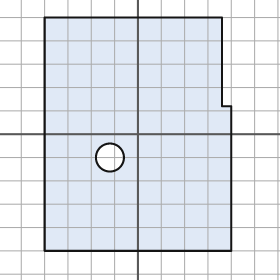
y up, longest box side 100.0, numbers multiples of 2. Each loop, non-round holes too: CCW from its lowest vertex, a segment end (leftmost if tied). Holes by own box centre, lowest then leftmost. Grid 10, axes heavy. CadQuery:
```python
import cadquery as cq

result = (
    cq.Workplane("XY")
    .moveTo(-40.0, -50.0)
    .lineTo(40.0, -50.0)
    .lineTo(40.0, 12.0)
    .lineTo(36.0, 12.0)
    .lineTo(36.0, 50.0)
    .lineTo(-40.0, 50.0)
    .close()
    .moveTo(-12.0, -10.0)
    .circle(6.0)
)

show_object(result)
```